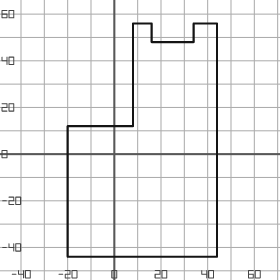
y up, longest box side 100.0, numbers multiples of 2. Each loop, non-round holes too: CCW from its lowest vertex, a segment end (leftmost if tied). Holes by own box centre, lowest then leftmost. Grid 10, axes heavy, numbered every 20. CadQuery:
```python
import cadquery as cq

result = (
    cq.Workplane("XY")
    .moveTo(-20.0, -44.0)
    .lineTo(44.0, -44.0)
    .lineTo(44.0, 56.0)
    .lineTo(34.0, 56.0)
    .lineTo(34.0, 48.0)
    .lineTo(16.0, 48.0)
    .lineTo(16.0, 56.0)
    .lineTo(8.0, 56.0)
    .lineTo(8.0, 12.0)
    .lineTo(-20.0, 12.0)
    .close()
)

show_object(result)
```